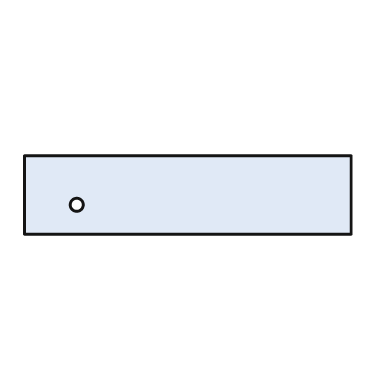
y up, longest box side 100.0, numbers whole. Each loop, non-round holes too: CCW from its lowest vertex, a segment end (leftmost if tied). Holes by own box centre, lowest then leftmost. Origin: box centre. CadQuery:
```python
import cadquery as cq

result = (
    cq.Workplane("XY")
    .moveTo(-50.0, -12.0)
    .lineTo(50.0, -12.0)
    .lineTo(50.0, 12.0)
    .lineTo(-50.0, 12.0)
    .close()
    .moveTo(-34.0, -3.0)
    .circle(2.0)
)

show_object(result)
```